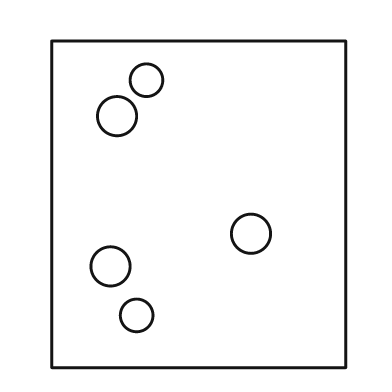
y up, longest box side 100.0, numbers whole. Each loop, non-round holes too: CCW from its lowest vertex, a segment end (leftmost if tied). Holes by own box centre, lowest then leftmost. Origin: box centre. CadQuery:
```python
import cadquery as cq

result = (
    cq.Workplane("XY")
    .moveTo(-45.0, -50.0)
    .lineTo(45.0, -50.0)
    .lineTo(45.0, 50.0)
    .lineTo(-45.0, 50.0)
    .close()
    .moveTo(-19.0, -34.0)
    .circle(5.0)
    .moveTo(-27.0, -19.0)
    .circle(6.0)
    .moveTo(16.0, -9.0)
    .circle(6.0)
    .moveTo(-25.0, 27.0)
    .circle(6.0)
    .moveTo(-16.0, 38.0)
    .circle(5.0)
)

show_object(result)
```